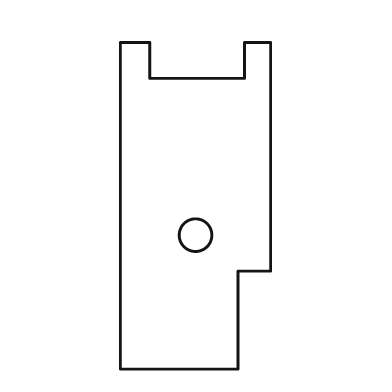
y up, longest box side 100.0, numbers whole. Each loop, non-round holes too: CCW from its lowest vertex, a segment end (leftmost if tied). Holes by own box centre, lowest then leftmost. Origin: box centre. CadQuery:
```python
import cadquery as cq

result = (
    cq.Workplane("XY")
    .moveTo(-23.0, -50.0)
    .lineTo(13.0, -50.0)
    .lineTo(13.0, -20.0)
    .lineTo(23.0, -20.0)
    .lineTo(23.0, 50.0)
    .lineTo(15.0, 50.0)
    .lineTo(15.0, 39.0)
    .lineTo(-14.0, 39.0)
    .lineTo(-14.0, 50.0)
    .lineTo(-23.0, 50.0)
    .close()
    .moveTo(0.0, -9.0)
    .circle(5.0)
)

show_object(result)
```